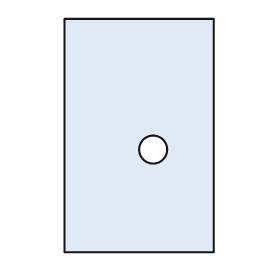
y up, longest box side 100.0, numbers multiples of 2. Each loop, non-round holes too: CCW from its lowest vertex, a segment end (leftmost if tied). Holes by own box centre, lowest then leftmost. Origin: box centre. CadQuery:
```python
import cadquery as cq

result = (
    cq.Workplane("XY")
    .moveTo(-32.0, -50.0)
    .lineTo(32.0, -50.0)
    .lineTo(32.0, 50.0)
    .lineTo(-32.0, 50.0)
    .close()
    .moveTo(6.0, -6.0)
    .circle(6.0)
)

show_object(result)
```